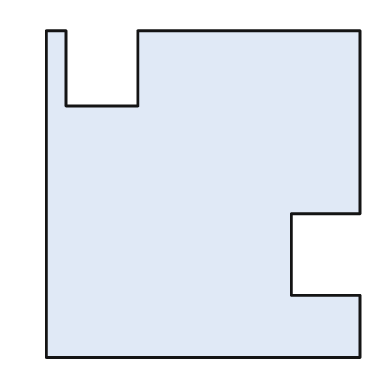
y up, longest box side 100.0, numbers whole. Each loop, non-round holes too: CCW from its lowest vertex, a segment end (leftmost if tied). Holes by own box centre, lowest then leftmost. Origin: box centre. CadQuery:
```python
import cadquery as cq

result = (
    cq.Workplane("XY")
    .moveTo(-48.0, -50.0)
    .lineTo(48.0, -50.0)
    .lineTo(48.0, -31.0)
    .lineTo(27.0, -31.0)
    .lineTo(27.0, -6.0)
    .lineTo(48.0, -6.0)
    .lineTo(48.0, 50.0)
    .lineTo(-20.0, 50.0)
    .lineTo(-20.0, 27.0)
    .lineTo(-42.0, 27.0)
    .lineTo(-42.0, 50.0)
    .lineTo(-48.0, 50.0)
    .close()
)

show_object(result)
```